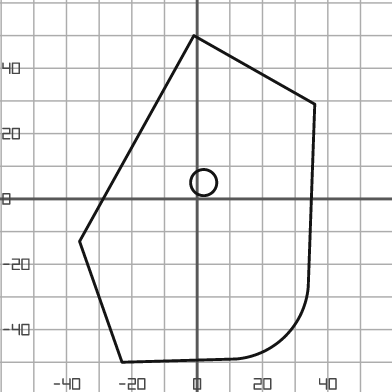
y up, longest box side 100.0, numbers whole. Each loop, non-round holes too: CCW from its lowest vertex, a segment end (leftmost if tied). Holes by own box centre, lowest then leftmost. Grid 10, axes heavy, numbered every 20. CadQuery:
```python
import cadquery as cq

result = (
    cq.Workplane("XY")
    .moveTo(-23.0, -50.0)
    .lineTo(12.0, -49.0)
    .threePointArc((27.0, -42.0), (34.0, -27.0))
    .lineTo(36.0, 29.0)
    .lineTo(-1.0, 50.0)
    .lineTo(-36.0, -13.0)
    .close()
    .moveTo(2.0, 5.0)
    .circle(4.0)
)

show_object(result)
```